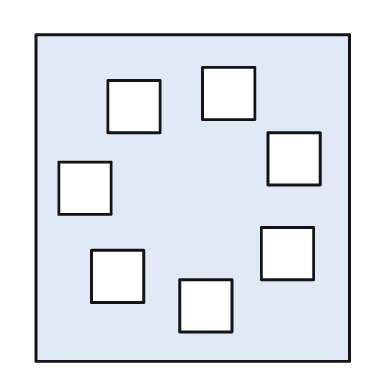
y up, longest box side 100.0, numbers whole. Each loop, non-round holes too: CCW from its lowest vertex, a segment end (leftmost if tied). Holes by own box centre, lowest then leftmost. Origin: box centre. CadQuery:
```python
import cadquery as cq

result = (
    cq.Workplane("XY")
    .moveTo(-48.0, -50.0)
    .lineTo(48.0, -50.0)
    .lineTo(48.0, 50.0)
    .lineTo(-48.0, 50.0)
    .close()
    .moveTo(-4.0, -41.0)
    .lineTo(12.0, -41.0)
    .lineTo(12.0, -25.0)
    .lineTo(-4.0, -25.0)
    .close()
    .moveTo(-31.0, -32.0)
    .lineTo(-15.0, -32.0)
    .lineTo(-15.0, -16.0)
    .lineTo(-31.0, -16.0)
    .close()
    .moveTo(21.0, -25.0)
    .lineTo(37.0, -25.0)
    .lineTo(37.0, -9.0)
    .lineTo(21.0, -9.0)
    .close()
    .moveTo(-41.0, -5.0)
    .lineTo(-25.0, -5.0)
    .lineTo(-25.0, 11.0)
    .lineTo(-41.0, 11.0)
    .close()
    .moveTo(23.0, 4.0)
    .lineTo(39.0, 4.0)
    .lineTo(39.0, 20.0)
    .lineTo(23.0, 20.0)
    .close()
    .moveTo(-26.0, 20.0)
    .lineTo(-10.0, 20.0)
    .lineTo(-10.0, 36.0)
    .lineTo(-26.0, 36.0)
    .close()
    .moveTo(3.0, 24.0)
    .lineTo(19.0, 24.0)
    .lineTo(19.0, 40.0)
    .lineTo(3.0, 40.0)
    .close()
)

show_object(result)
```